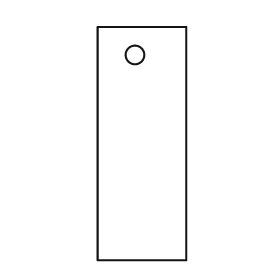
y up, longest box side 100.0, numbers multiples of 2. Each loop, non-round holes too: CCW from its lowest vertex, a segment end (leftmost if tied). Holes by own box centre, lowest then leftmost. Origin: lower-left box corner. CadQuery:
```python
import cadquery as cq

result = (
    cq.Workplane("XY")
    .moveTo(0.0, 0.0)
    .lineTo(38.0, 0.0)
    .lineTo(38.0, 100.0)
    .lineTo(0.0, 100.0)
    .close()
    .moveTo(16.0, 88.0)
    .circle(4.0)
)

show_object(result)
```